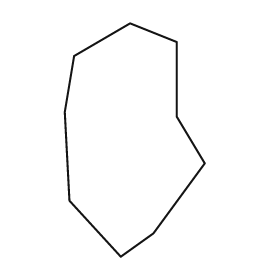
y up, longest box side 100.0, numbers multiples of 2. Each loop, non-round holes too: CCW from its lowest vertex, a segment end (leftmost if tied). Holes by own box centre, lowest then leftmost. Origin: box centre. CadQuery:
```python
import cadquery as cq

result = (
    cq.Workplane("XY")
    .moveTo(-6.0, -50.0)
    .lineTo(8.0, -40.0)
    .lineTo(30.0, -10.0)
    .lineTo(18.0, 10.0)
    .lineTo(18.0, 42.0)
    .lineTo(-2.0, 50.0)
    .lineTo(-26.0, 36.0)
    .lineTo(-30.0, 12.0)
    .lineTo(-28.0, -26.0)
    .close()
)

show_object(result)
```